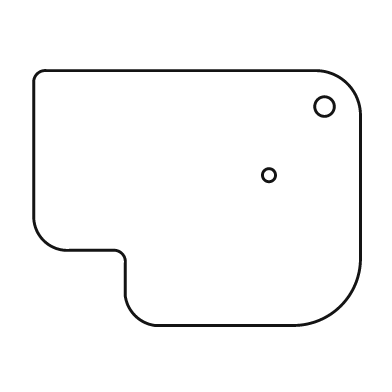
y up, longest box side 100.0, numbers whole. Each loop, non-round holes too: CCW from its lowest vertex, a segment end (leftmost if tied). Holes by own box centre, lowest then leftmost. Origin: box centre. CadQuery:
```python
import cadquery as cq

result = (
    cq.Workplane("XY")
    .moveTo(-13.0, -39.0)
    .lineTo(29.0, -39.0)
    .threePointArc((44.0, -33.0), (50.0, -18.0))
    .lineTo(50.0, 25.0)
    .threePointArc((46.0, 35.0), (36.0, 39.0))
    .lineTo(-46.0, 39.0)
    .threePointArc((-49.0, 38.0), (-50.0, 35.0))
    .lineTo(-50.0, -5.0)
    .threePointArc((-47.0, -13.0), (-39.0, -16.0))
    .lineTo(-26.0, -16.0)
    .threePointArc((-23.0, -17.0), (-22.0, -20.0))
    .lineTo(-22.0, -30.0)
    .threePointArc((-19.0, -36.0), (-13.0, -39.0))
    .close()
    .moveTo(22.0, 7.0)
    .circle(2.0)
    .moveTo(39.0, 28.0)
    .circle(3.0)
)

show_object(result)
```